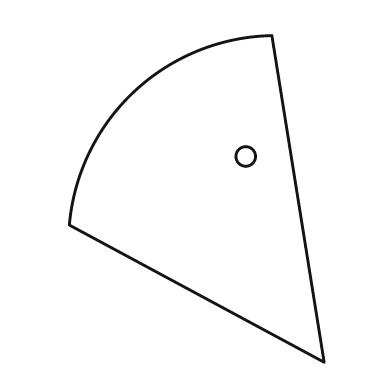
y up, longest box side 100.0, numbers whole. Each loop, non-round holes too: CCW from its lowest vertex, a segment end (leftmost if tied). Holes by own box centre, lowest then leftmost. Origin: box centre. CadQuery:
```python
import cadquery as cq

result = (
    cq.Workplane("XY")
    .moveTo(39.0, -50.0)
    .lineTo(23.0, 50.0)
    .threePointArc((-19.0, 33.0), (-39.0, -8.0))
    .close()
    .moveTo(15.0, 13.0)
    .circle(3.0)
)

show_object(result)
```